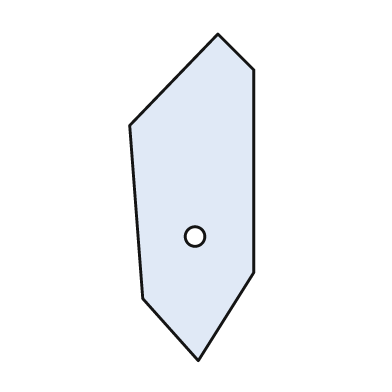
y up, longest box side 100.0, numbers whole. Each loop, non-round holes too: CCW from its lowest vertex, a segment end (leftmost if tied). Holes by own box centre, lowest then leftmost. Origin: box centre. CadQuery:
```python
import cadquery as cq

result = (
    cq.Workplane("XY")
    .moveTo(2.0, -50.0)
    .lineTo(19.0, -23.0)
    .lineTo(19.0, 39.0)
    .lineTo(8.0, 50.0)
    .lineTo(-19.0, 22.0)
    .lineTo(-15.0, -31.0)
    .close()
    .moveTo(1.0, -12.0)
    .circle(3.0)
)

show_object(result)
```